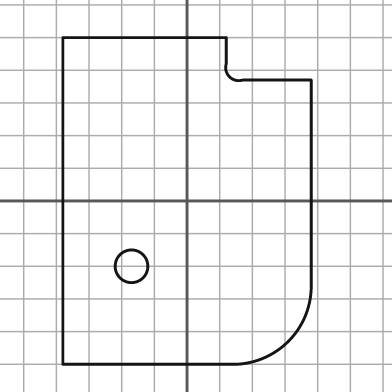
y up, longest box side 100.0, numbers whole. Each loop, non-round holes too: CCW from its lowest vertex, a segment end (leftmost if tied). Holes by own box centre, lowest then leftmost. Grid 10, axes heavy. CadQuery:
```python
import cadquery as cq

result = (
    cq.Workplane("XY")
    .moveTo(-38.0, -50.0)
    .lineTo(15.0, -50.0)
    .threePointArc((31.0, -43.0), (38.0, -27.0))
    .lineTo(38.0, 37.0)
    .lineTo(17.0, 37.0)
    .threePointArc((13.0, 38.0), (12.0, 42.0))
    .lineTo(12.0, 50.0)
    .lineTo(-38.0, 50.0)
    .close()
    .moveTo(-17.0, -20.0)
    .circle(5.0)
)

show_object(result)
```